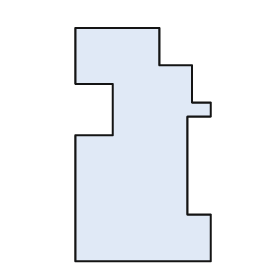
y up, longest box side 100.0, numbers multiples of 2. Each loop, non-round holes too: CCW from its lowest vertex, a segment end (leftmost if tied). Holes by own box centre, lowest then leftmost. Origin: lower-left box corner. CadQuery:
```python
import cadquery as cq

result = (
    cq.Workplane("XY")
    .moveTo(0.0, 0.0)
    .lineTo(58.0, 0.0)
    .lineTo(58.0, 20.0)
    .lineTo(48.0, 20.0)
    .lineTo(48.0, 62.0)
    .lineTo(58.0, 62.0)
    .lineTo(58.0, 68.0)
    .lineTo(50.0, 68.0)
    .lineTo(50.0, 84.0)
    .lineTo(36.0, 84.0)
    .lineTo(36.0, 100.0)
    .lineTo(0.0, 100.0)
    .lineTo(0.0, 76.0)
    .lineTo(16.0, 76.0)
    .lineTo(16.0, 54.0)
    .lineTo(0.0, 54.0)
    .close()
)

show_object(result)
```